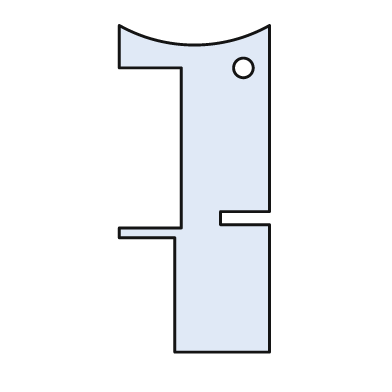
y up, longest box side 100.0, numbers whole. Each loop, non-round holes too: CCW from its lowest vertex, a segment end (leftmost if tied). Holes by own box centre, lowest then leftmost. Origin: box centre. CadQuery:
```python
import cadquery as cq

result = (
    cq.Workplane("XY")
    .moveTo(-6.0, -50.0)
    .lineTo(23.0, -50.0)
    .lineTo(23.0, -11.0)
    .lineTo(8.0, -11.0)
    .lineTo(8.0, -7.0)
    .lineTo(23.0, -7.0)
    .lineTo(23.0, 50.0)
    .threePointArc((0.0, 44.0), (-23.0, 50.0))
    .lineTo(-23.0, 37.0)
    .lineTo(-4.0, 37.0)
    .lineTo(-4.0, -12.0)
    .lineTo(-23.0, -12.0)
    .lineTo(-23.0, -15.0)
    .lineTo(-6.0, -15.0)
    .close()
    .moveTo(15.0, 37.0)
    .circle(3.0)
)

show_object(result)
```